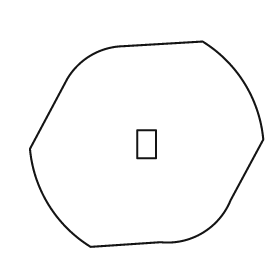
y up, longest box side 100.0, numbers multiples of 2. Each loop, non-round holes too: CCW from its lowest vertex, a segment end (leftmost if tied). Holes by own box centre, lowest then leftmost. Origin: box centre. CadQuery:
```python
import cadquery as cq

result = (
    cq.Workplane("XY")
    .moveTo(-24.0, -44.0)
    .lineTo(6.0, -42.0)
    .threePointArc((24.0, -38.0), (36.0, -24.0))
    .lineTo(50.0, 2.0)
    .threePointArc((42.0, 26.0), (24.0, 44.0))
    .lineTo(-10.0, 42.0)
    .threePointArc((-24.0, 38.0), (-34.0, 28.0))
    .lineTo(-50.0, -2.0)
    .threePointArc((-42.0, -26.0), (-24.0, -44.0))
    .close()
    .moveTo(-4.0, -6.0)
    .lineTo(4.0, -6.0)
    .lineTo(4.0, 6.0)
    .lineTo(-4.0, 6.0)
    .close()
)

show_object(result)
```